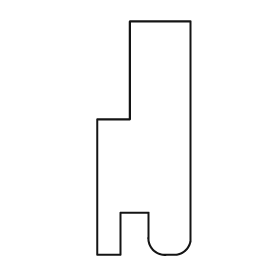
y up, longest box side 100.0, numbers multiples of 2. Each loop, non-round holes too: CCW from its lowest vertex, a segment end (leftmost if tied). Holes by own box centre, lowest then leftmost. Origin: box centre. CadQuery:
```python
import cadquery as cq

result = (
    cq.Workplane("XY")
    .moveTo(-20.0, -50.0)
    .lineTo(-10.0, -50.0)
    .lineTo(-10.0, -32.0)
    .lineTo(2.0, -32.0)
    .lineTo(2.0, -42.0)
    .threePointArc((4.0, -48.0), (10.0, -50.0))
    .lineTo(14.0, -50.0)
    .threePointArc((18.0, -48.0), (20.0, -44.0))
    .lineTo(20.0, 50.0)
    .lineTo(-6.0, 50.0)
    .lineTo(-6.0, 8.0)
    .lineTo(-20.0, 8.0)
    .close()
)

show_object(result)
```